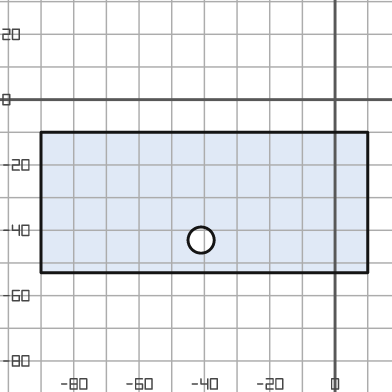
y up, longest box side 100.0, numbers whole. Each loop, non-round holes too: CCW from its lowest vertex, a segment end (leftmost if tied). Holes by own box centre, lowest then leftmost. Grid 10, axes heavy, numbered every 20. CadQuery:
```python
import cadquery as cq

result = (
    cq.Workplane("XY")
    .moveTo(-90.0, -53.0)
    .lineTo(10.0, -53.0)
    .lineTo(10.0, -10.0)
    .lineTo(-90.0, -10.0)
    .close()
    .moveTo(-41.0, -43.0)
    .circle(4.0)
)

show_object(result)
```